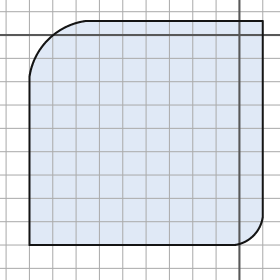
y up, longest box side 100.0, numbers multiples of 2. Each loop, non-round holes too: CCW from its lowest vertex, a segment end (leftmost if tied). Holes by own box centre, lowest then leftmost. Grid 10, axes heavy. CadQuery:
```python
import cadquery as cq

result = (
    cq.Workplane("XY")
    .moveTo(-90.0, -90.0)
    .lineTo(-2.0, -90.0)
    .threePointArc((6.0, -86.0), (10.0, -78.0))
    .lineTo(10.0, 6.0)
    .lineTo(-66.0, 6.0)
    .threePointArc((-82.0, -2.0), (-90.0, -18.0))
    .close()
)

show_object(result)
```